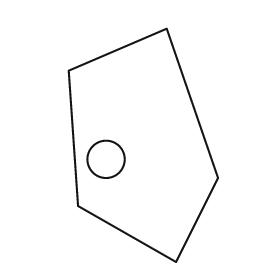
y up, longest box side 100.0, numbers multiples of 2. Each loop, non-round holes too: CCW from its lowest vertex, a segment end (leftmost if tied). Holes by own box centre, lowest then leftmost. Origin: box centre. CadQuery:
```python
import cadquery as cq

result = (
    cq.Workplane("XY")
    .moveTo(14.0, -50.0)
    .lineTo(32.0, -14.0)
    .lineTo(10.0, 50.0)
    .lineTo(-32.0, 32.0)
    .lineTo(-28.0, -26.0)
    .close()
    .moveTo(-16.0, -6.0)
    .circle(8.0)
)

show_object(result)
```